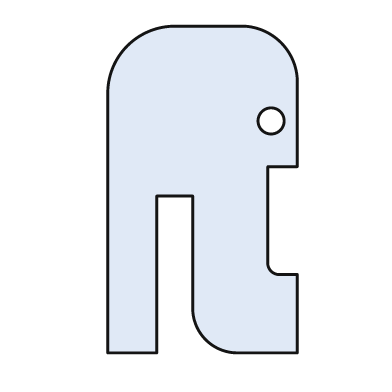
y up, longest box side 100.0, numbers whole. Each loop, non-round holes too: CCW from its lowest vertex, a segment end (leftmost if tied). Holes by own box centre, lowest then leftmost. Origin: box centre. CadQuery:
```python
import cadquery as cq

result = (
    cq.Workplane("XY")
    .moveTo(-29.0, -50.0)
    .lineTo(-14.0, -50.0)
    .lineTo(-14.0, -2.0)
    .lineTo(-3.0, -2.0)
    .lineTo(-3.0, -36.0)
    .threePointArc((1.0, -46.0), (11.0, -50.0))
    .lineTo(29.0, -50.0)
    .lineTo(29.0, -26.0)
    .lineTo(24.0, -26.0)
    .threePointArc((21.0, -25.0), (20.0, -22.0))
    .lineTo(20.0, 7.0)
    .lineTo(29.0, 7.0)
    .lineTo(29.0, 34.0)
    .threePointArc((24.0, 45.0), (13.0, 50.0))
    .lineTo(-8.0, 50.0)
    .threePointArc((-23.0, 44.0), (-29.0, 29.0))
    .close()
    .moveTo(21.0, 21.0)
    .circle(4.0)
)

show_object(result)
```